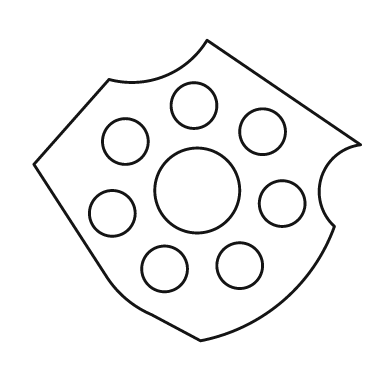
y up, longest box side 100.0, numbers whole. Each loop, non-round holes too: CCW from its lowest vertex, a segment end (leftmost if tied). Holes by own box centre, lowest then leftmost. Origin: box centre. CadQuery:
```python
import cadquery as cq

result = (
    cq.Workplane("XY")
    .moveTo(1.0, -46.0)
    .threePointArc((26.0, -34.0), (42.0, -11.0))
    .threePointArc((38.0, 4.0), (50.0, 14.0))
    .lineTo(3.0, 46.0)
    .threePointArc((-10.0, 35.0), (-27.0, 34.0))
    .lineTo(-50.0, 8.0)
    .lineTo(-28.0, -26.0)
    .threePointArc((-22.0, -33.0), (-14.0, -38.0))
    .close()
    .moveTo(-10.0, -24.0)
    .circle(7.0)
    .moveTo(13.0, -23.0)
    .circle(7.0)
    .moveTo(-26.0, -7.0)
    .circle(7.0)
    .moveTo(26.0, -4.0)
    .circle(7.0)
    .moveTo(0.0, 0.0)
    .circle(13.0)
    .moveTo(-22.0, 15.0)
    .circle(7.0)
    .moveTo(20.0, 18.0)
    .circle(7.0)
    .moveTo(-1.0, 26.0)
    .circle(7.0)
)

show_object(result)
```